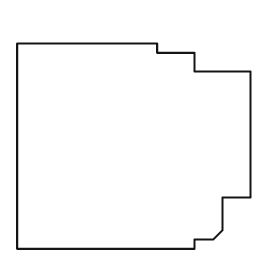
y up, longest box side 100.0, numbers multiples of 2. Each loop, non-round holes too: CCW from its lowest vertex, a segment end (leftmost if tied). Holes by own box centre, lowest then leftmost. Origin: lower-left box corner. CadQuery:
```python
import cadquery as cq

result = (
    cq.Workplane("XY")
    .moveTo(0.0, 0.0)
    .lineTo(76.0, 0.0)
    .lineTo(76.0, 4.0)
    .lineTo(84.0, 4.0)
    .lineTo(88.0, 8.0)
    .lineTo(88.0, 22.0)
    .lineTo(100.0, 22.0)
    .lineTo(100.0, 76.0)
    .lineTo(76.0, 76.0)
    .lineTo(76.0, 84.0)
    .lineTo(60.0, 84.0)
    .lineTo(60.0, 88.0)
    .lineTo(0.0, 88.0)
    .close()
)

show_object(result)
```